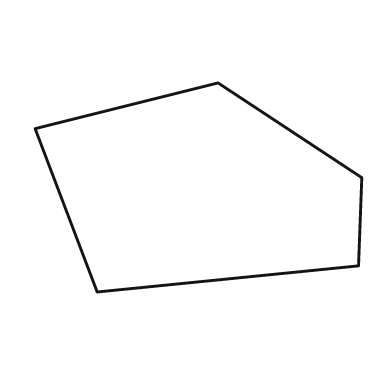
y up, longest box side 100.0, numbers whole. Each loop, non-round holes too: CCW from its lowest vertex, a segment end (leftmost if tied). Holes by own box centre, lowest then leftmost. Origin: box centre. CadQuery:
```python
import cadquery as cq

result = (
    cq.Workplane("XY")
    .moveTo(-31.0, -32.0)
    .lineTo(49.0, -24.0)
    .lineTo(50.0, 3.0)
    .lineTo(6.0, 32.0)
    .lineTo(-50.0, 18.0)
    .close()
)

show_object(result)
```